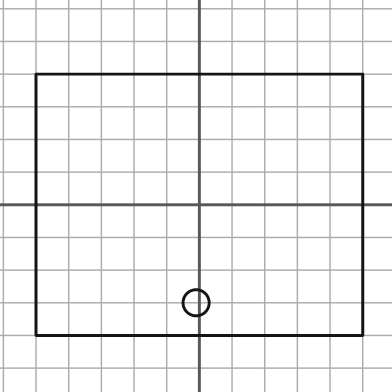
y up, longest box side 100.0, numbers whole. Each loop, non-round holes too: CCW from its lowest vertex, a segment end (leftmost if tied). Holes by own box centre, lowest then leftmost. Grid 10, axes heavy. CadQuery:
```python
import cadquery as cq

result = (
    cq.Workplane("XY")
    .moveTo(-50.0, -40.0)
    .lineTo(50.0, -40.0)
    .lineTo(50.0, 40.0)
    .lineTo(-50.0, 40.0)
    .close()
    .moveTo(-1.0, -30.0)
    .circle(4.0)
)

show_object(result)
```